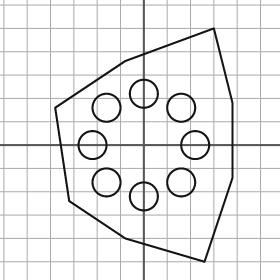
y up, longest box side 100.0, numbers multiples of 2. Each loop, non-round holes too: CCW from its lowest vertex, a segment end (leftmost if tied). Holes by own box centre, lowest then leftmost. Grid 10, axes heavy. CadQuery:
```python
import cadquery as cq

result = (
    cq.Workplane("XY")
    .moveTo(26.0, -50.0)
    .lineTo(38.0, -14.0)
    .lineTo(38.0, 18.0)
    .lineTo(30.0, 50.0)
    .lineTo(-8.0, 36.0)
    .lineTo(-38.0, 16.0)
    .lineTo(-32.0, -24.0)
    .lineTo(-8.0, -40.0)
    .close()
    .moveTo(0.0, -22.0)
    .circle(6.0)
    .moveTo(-16.0, -16.0)
    .circle(6.0)
    .moveTo(16.0, -16.0)
    .circle(6.0)
    .moveTo(-22.0, 0.0)
    .circle(6.0)
    .moveTo(22.0, 0.0)
    .circle(6.0)
    .moveTo(-16.0, 16.0)
    .circle(6.0)
    .moveTo(16.0, 16.0)
    .circle(6.0)
    .moveTo(0.0, 22.0)
    .circle(6.0)
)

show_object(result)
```